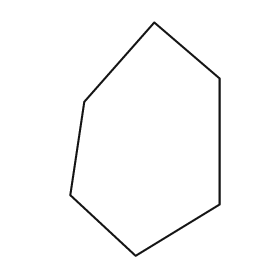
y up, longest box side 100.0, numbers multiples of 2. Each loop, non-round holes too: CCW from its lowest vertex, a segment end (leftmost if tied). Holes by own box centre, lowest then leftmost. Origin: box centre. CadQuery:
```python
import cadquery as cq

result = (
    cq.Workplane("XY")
    .moveTo(-4.0, -50.0)
    .lineTo(32.0, -28.0)
    .lineTo(32.0, 26.0)
    .lineTo(4.0, 50.0)
    .lineTo(-26.0, 16.0)
    .lineTo(-32.0, -24.0)
    .close()
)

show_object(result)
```